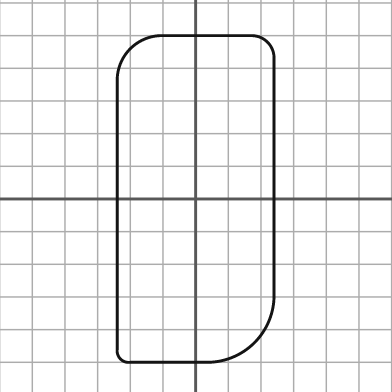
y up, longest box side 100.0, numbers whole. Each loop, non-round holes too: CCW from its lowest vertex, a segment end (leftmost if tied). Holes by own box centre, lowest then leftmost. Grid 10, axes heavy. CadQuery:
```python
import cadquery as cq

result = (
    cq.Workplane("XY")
    .moveTo(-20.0, -50.0)
    .lineTo(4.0, -50.0)
    .threePointArc((18.0, -44.0), (24.0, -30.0))
    .lineTo(24.0, 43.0)
    .threePointArc((22.0, 48.0), (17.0, 50.0))
    .lineTo(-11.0, 50.0)
    .threePointArc((-20.0, 46.0), (-24.0, 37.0))
    .lineTo(-24.0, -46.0)
    .threePointArc((-23.0, -49.0), (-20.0, -50.0))
    .close()
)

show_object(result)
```